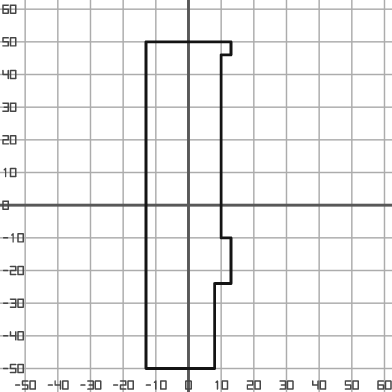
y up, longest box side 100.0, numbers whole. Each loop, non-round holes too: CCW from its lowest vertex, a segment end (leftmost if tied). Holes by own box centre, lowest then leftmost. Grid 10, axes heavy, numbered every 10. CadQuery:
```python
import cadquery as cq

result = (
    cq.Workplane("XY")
    .moveTo(-13.0, -50.0)
    .lineTo(8.0, -50.0)
    .lineTo(8.0, -24.0)
    .lineTo(13.0, -24.0)
    .lineTo(13.0, -10.0)
    .lineTo(10.0, -10.0)
    .lineTo(10.0, 46.0)
    .lineTo(13.0, 46.0)
    .lineTo(13.0, 50.0)
    .lineTo(-13.0, 50.0)
    .close()
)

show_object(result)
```